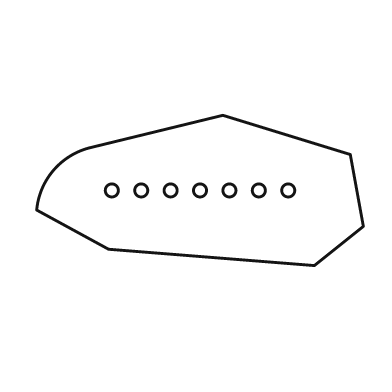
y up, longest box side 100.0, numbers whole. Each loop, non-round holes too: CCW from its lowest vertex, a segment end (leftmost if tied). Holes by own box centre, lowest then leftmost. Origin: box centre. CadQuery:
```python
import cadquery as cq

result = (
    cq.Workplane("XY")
    .moveTo(35.0, -23.0)
    .lineTo(50.0, -11.0)
    .lineTo(46.0, 11.0)
    .lineTo(7.0, 23.0)
    .lineTo(-34.0, 13.0)
    .threePointArc((-45.0, 6.0), (-50.0, -6.0))
    .lineTo(-28.0, -18.0)
    .close()
    .moveTo(-27.0, 0.0)
    .circle(2.0)
    .moveTo(-18.0, 0.0)
    .circle(2.0)
    .moveTo(-9.0, 0.0)
    .circle(2.0)
    .moveTo(0.0, 0.0)
    .circle(2.0)
    .moveTo(9.0, 0.0)
    .circle(2.0)
    .moveTo(18.0, 0.0)
    .circle(2.0)
    .moveTo(27.0, 0.0)
    .circle(2.0)
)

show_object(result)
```